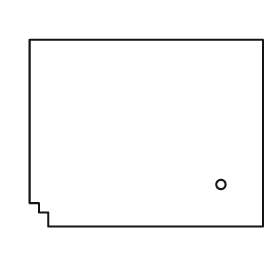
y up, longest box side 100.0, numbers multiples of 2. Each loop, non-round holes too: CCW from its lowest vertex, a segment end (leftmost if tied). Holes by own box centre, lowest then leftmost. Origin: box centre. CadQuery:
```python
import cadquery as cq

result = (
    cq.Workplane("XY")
    .moveTo(-42.0, -40.0)
    .lineTo(50.0, -40.0)
    .lineTo(50.0, 40.0)
    .lineTo(-50.0, 40.0)
    .lineTo(-50.0, -30.0)
    .lineTo(-46.0, -30.0)
    .lineTo(-46.0, -34.0)
    .lineTo(-42.0, -34.0)
    .close()
    .moveTo(32.0, -22.0)
    .circle(2.0)
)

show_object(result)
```